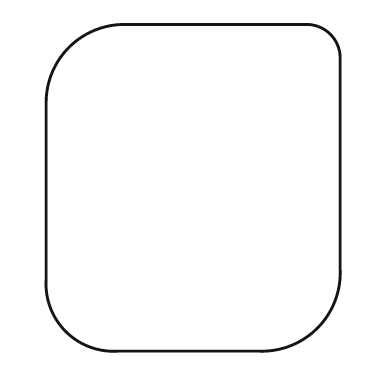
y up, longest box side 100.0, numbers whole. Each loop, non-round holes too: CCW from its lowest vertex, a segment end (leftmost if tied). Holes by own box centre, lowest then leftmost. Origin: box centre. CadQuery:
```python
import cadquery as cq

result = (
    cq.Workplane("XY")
    .moveTo(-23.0, -50.0)
    .lineTo(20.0, -50.0)
    .threePointArc((38.0, -43.0), (45.0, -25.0))
    .lineTo(45.0, 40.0)
    .threePointArc((42.0, 47.0), (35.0, 50.0))
    .lineTo(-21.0, 50.0)
    .threePointArc((-38.0, 43.0), (-45.0, 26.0))
    .lineTo(-45.0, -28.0)
    .threePointArc((-39.0, -44.0), (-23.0, -50.0))
    .close()
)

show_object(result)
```